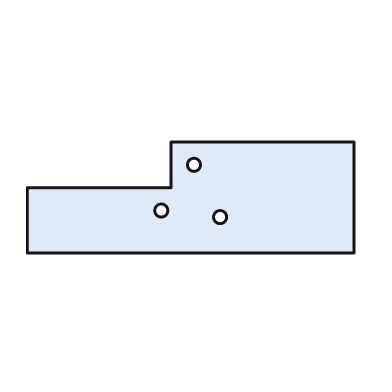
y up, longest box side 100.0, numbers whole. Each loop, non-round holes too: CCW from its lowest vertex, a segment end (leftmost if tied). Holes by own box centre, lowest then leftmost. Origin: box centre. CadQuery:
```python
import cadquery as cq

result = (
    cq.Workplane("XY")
    .moveTo(-50.0, -17.0)
    .lineTo(50.0, -17.0)
    .lineTo(50.0, 17.0)
    .lineTo(-6.0, 17.0)
    .lineTo(-6.0, 3.0)
    .lineTo(-50.0, 3.0)
    .close()
    .moveTo(9.0, -6.0)
    .circle(2.0)
    .moveTo(-9.0, -4.0)
    .circle(2.0)
    .moveTo(1.0, 10.0)
    .circle(2.0)
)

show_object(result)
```